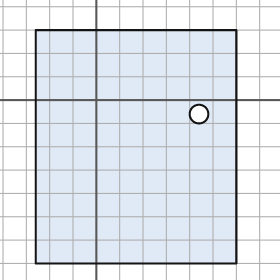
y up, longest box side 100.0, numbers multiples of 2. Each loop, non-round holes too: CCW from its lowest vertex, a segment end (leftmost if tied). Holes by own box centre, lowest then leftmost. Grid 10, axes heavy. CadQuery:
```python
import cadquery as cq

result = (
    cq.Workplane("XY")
    .moveTo(-26.0, -70.0)
    .lineTo(60.0, -70.0)
    .lineTo(60.0, 30.0)
    .lineTo(-26.0, 30.0)
    .close()
    .moveTo(44.0, -6.0)
    .circle(4.0)
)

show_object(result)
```